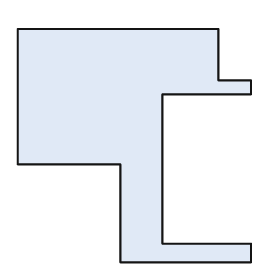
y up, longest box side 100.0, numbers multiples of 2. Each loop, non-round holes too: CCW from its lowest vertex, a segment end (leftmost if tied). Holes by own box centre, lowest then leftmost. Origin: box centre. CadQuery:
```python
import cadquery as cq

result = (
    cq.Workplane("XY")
    .moveTo(-6.0, -50.0)
    .lineTo(50.0, -50.0)
    .lineTo(50.0, -42.0)
    .lineTo(12.0, -42.0)
    .lineTo(12.0, 22.0)
    .lineTo(50.0, 22.0)
    .lineTo(50.0, 28.0)
    .lineTo(36.0, 28.0)
    .lineTo(36.0, 50.0)
    .lineTo(-50.0, 50.0)
    .lineTo(-50.0, -8.0)
    .lineTo(-6.0, -8.0)
    .close()
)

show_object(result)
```